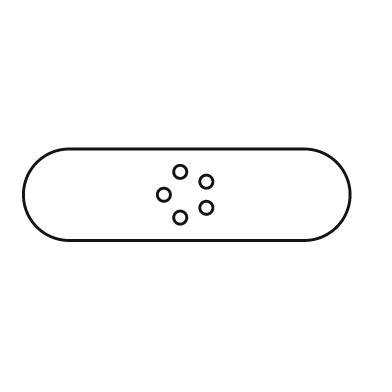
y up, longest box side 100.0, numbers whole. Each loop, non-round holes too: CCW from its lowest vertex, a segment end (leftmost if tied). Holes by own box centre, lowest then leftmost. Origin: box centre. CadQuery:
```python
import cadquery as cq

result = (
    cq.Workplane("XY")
    .moveTo(-36.0, -14.0)
    .lineTo(36.0, -14.0)
    .threePointArc((50.0, 0.0), (36.0, 14.0))
    .lineTo(-36.0, 14.0)
    .threePointArc((-50.0, 0.0), (-36.0, -14.0))
    .close()
    .moveTo(-2.0, -7.0)
    .circle(2.0)
    .moveTo(6.0, -4.0)
    .circle(2.0)
    .moveTo(-7.0, 0.0)
    .circle(2.0)
    .moveTo(6.0, 4.0)
    .circle(2.0)
    .moveTo(-2.0, 7.0)
    .circle(2.0)
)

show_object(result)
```